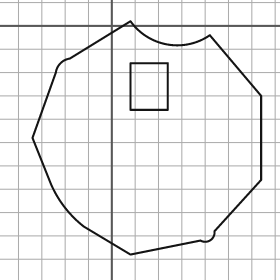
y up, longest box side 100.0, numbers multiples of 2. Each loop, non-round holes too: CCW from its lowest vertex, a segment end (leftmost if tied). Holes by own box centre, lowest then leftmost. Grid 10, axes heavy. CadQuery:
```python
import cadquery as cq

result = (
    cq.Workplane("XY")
    .moveTo(8.0, -98.0)
    .lineTo(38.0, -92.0)
    .threePointArc((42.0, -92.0), (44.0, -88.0))
    .lineTo(64.0, -66.0)
    .lineTo(64.0, -30.0)
    .lineTo(42.0, -4.0)
    .threePointArc((24.0, -8.0), (8.0, 2.0))
    .lineTo(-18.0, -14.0)
    .threePointArc((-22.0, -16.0), (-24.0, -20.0))
    .lineTo(-34.0, -48.0)
    .lineTo(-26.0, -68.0)
    .threePointArc((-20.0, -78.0), (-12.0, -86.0))
    .close()
    .moveTo(8.0, -36.0)
    .lineTo(24.0, -36.0)
    .lineTo(24.0, -16.0)
    .lineTo(8.0, -16.0)
    .close()
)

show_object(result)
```